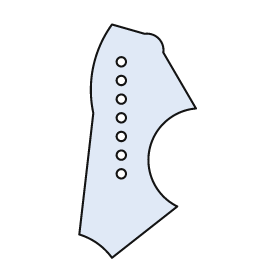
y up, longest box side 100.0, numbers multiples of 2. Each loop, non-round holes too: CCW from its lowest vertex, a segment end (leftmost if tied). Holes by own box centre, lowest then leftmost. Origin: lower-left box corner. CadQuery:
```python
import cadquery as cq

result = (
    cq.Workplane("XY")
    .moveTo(14.0, 0.0)
    .lineTo(42.0, 22.0)
    .threePointArc((30.0, 46.0), (50.0, 64.0))
    .lineTo(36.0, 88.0)
    .threePointArc((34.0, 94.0), (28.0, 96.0))
    .lineTo(14.0, 100.0)
    .threePointArc((6.0, 82.0), (6.0, 62.0))
    .lineTo(0.0, 10.0)
    .threePointArc((8.0, 6.0), (14.0, 0.0))
    .close()
    .moveTo(18.0, 36.0)
    .circle(2.0)
    .moveTo(18.0, 44.0)
    .circle(2.0)
    .moveTo(18.0, 52.0)
    .circle(2.0)
    .moveTo(18.0, 60.0)
    .circle(2.0)
    .moveTo(18.0, 68.0)
    .circle(2.0)
    .moveTo(18.0, 76.0)
    .circle(2.0)
    .moveTo(18.0, 84.0)
    .circle(2.0)
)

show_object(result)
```